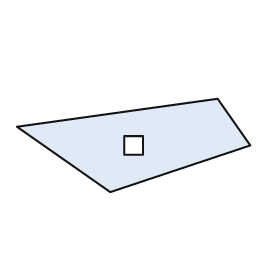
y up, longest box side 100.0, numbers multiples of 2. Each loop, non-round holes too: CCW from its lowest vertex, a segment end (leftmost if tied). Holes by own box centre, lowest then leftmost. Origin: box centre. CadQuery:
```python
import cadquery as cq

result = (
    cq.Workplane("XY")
    .moveTo(-10.0, -20.0)
    .lineTo(50.0, 0.0)
    .lineTo(36.0, 20.0)
    .lineTo(-50.0, 8.0)
    .close()
    .moveTo(-4.0, -4.0)
    .lineTo(4.0, -4.0)
    .lineTo(4.0, 4.0)
    .lineTo(-4.0, 4.0)
    .close()
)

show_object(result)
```